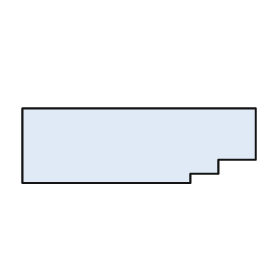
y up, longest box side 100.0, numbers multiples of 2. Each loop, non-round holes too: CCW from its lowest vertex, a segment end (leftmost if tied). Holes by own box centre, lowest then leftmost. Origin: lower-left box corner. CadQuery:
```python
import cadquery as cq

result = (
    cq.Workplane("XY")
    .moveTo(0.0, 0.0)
    .lineTo(72.0, 0.0)
    .lineTo(72.0, 4.0)
    .lineTo(84.0, 4.0)
    .lineTo(84.0, 10.0)
    .lineTo(100.0, 10.0)
    .lineTo(100.0, 32.0)
    .lineTo(0.0, 32.0)
    .close()
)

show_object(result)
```